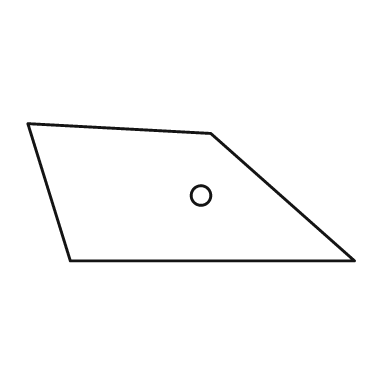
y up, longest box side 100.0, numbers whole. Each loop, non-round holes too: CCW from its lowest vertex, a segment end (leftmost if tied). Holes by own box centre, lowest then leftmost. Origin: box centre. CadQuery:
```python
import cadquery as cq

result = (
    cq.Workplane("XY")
    .moveTo(-37.0, -21.0)
    .lineTo(50.0, -21.0)
    .lineTo(6.0, 18.0)
    .lineTo(-50.0, 21.0)
    .close()
    .moveTo(3.0, -1.0)
    .circle(3.0)
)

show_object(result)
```